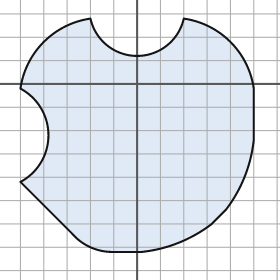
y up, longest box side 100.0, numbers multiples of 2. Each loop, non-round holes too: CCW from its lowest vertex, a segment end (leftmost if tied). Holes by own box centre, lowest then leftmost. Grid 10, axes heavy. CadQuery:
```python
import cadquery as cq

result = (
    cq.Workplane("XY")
    .moveTo(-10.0, -72.0)
    .lineTo(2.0, -72.0)
    .threePointArc((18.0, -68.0), (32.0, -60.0))
    .lineTo(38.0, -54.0)
    .threePointArc((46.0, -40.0), (50.0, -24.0))
    .lineTo(50.0, -2.0)
    .threePointArc((40.0, 18.0), (20.0, 28.0))
    .threePointArc((0.0, 12.0), (-20.0, 28.0))
    .threePointArc((-40.0, 18.0), (-50.0, -2.0))
    .threePointArc((-38.0, -22.0), (-50.0, -42.0))
    .lineTo(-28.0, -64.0)
    .threePointArc((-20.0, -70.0), (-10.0, -72.0))
    .close()
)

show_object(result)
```